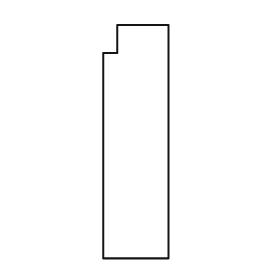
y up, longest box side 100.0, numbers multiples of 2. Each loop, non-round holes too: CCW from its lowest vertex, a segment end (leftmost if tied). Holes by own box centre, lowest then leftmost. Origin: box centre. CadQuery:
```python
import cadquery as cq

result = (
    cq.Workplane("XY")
    .moveTo(-14.0, -50.0)
    .lineTo(14.0, -50.0)
    .lineTo(14.0, 50.0)
    .lineTo(-8.0, 50.0)
    .lineTo(-8.0, 38.0)
    .lineTo(-14.0, 38.0)
    .close()
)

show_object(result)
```